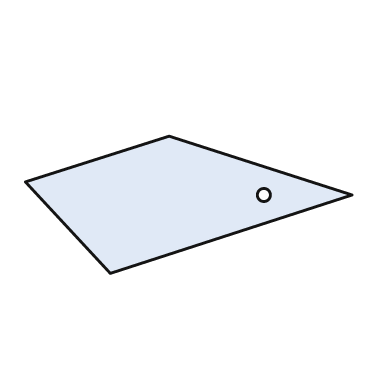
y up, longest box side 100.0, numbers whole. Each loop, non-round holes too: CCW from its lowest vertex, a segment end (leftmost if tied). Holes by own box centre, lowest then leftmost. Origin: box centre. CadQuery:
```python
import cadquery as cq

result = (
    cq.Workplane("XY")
    .moveTo(-24.0, -21.0)
    .lineTo(50.0, 3.0)
    .lineTo(-6.0, 21.0)
    .lineTo(-50.0, 7.0)
    .close()
    .moveTo(23.0, 3.0)
    .circle(2.0)
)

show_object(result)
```